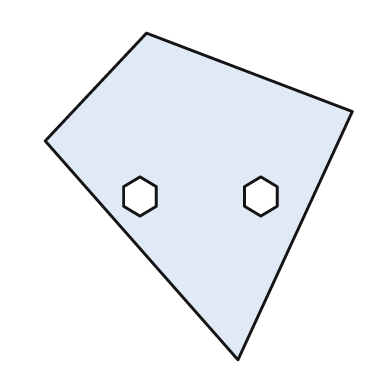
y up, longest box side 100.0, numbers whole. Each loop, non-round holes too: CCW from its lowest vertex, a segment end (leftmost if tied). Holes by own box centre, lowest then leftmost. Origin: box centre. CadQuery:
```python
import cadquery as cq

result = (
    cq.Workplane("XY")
    .moveTo(12.0, -50.0)
    .lineTo(47.0, 26.0)
    .lineTo(-16.0, 50.0)
    .lineTo(-47.0, 17.0)
    .close()
    .moveTo(-18.0, -6.0)
    .lineTo(-13.0, -3.0)
    .lineTo(-13.0, 3.0)
    .lineTo(-18.0, 6.0)
    .lineTo(-23.0, 3.0)
    .lineTo(-23.0, -3.0)
    .close()
    .moveTo(19.0, -6.0)
    .lineTo(24.0, -3.0)
    .lineTo(24.0, 3.0)
    .lineTo(19.0, 6.0)
    .lineTo(14.0, 3.0)
    .lineTo(14.0, -3.0)
    .close()
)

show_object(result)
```